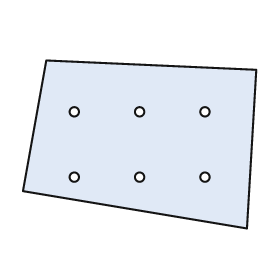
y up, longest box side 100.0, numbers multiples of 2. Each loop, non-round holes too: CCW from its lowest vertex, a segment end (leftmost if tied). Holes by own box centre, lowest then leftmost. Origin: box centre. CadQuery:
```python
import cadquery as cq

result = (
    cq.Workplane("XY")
    .moveTo(46.0, -36.0)
    .lineTo(50.0, 32.0)
    .lineTo(-40.0, 36.0)
    .lineTo(-50.0, -20.0)
    .close()
    .moveTo(-28.0, -14.0)
    .circle(2.0)
    .moveTo(0.0, -14.0)
    .circle(2.0)
    .moveTo(28.0, -14.0)
    .circle(2.0)
    .moveTo(-28.0, 14.0)
    .circle(2.0)
    .moveTo(0.0, 14.0)
    .circle(2.0)
    .moveTo(28.0, 14.0)
    .circle(2.0)
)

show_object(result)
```